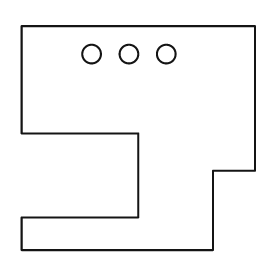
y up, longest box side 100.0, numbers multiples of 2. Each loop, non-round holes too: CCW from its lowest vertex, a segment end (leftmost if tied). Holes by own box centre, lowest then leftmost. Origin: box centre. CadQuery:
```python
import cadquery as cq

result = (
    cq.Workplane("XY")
    .moveTo(-50.0, -48.0)
    .lineTo(32.0, -48.0)
    .lineTo(32.0, -14.0)
    .lineTo(50.0, -14.0)
    .lineTo(50.0, 48.0)
    .lineTo(-50.0, 48.0)
    .lineTo(-50.0, 2.0)
    .lineTo(0.0, 2.0)
    .lineTo(0.0, -34.0)
    .lineTo(-50.0, -34.0)
    .close()
    .moveTo(-20.0, 36.0)
    .circle(4.0)
    .moveTo(-4.0, 36.0)
    .circle(4.0)
    .moveTo(12.0, 36.0)
    .circle(4.0)
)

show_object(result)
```